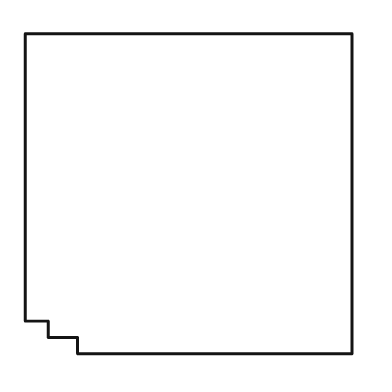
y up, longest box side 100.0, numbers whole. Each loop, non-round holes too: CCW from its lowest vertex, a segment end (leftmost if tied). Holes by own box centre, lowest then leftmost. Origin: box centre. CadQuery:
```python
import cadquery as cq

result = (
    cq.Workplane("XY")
    .moveTo(-34.0, -49.0)
    .lineTo(50.0, -49.0)
    .lineTo(50.0, 49.0)
    .lineTo(-50.0, 49.0)
    .lineTo(-50.0, -39.0)
    .lineTo(-43.0, -39.0)
    .lineTo(-43.0, -44.0)
    .lineTo(-34.0, -44.0)
    .close()
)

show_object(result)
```